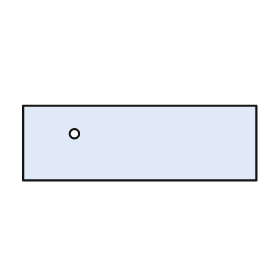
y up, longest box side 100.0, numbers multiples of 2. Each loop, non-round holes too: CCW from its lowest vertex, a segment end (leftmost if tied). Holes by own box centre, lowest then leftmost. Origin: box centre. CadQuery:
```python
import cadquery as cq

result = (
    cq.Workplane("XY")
    .moveTo(-50.0, -16.0)
    .lineTo(50.0, -16.0)
    .lineTo(50.0, 16.0)
    .lineTo(-50.0, 16.0)
    .close()
    .moveTo(-28.0, 4.0)
    .circle(2.0)
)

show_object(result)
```